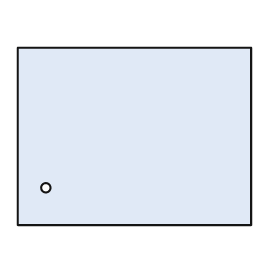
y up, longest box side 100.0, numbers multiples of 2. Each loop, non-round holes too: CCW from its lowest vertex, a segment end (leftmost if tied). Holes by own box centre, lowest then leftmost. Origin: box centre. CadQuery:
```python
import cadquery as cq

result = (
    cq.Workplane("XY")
    .moveTo(-50.0, -38.0)
    .lineTo(50.0, -38.0)
    .lineTo(50.0, 38.0)
    .lineTo(-50.0, 38.0)
    .close()
    .moveTo(-38.0, -22.0)
    .circle(2.0)
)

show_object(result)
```